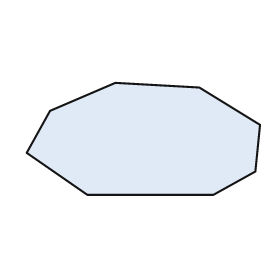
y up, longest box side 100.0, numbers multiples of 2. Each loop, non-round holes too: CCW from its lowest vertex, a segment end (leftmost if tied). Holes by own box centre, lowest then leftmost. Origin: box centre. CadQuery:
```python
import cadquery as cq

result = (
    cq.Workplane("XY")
    .moveTo(-24.0, -24.0)
    .lineTo(30.0, -24.0)
    .lineTo(48.0, -14.0)
    .lineTo(50.0, 6.0)
    .lineTo(24.0, 22.0)
    .lineTo(-12.0, 24.0)
    .lineTo(-40.0, 12.0)
    .lineTo(-50.0, -6.0)
    .close()
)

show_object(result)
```